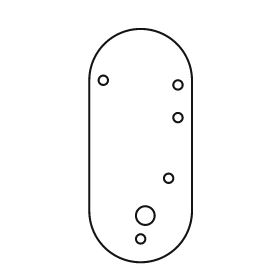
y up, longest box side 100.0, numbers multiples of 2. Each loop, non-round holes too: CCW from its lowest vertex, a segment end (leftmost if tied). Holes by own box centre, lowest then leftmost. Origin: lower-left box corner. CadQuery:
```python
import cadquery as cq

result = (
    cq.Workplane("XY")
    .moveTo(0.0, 22.0)
    .threePointArc((22.0, 0.0), (44.0, 22.0))
    .lineTo(44.0, 78.0)
    .threePointArc((22.0, 100.0), (0.0, 78.0))
    .close()
    .moveTo(22.0, 10.0)
    .circle(2.0)
    .moveTo(24.0, 20.0)
    .circle(4.0)
    .moveTo(34.0, 36.0)
    .circle(2.0)
    .moveTo(38.0, 62.0)
    .circle(2.0)
    .moveTo(38.0, 76.0)
    .circle(2.0)
    .moveTo(6.0, 78.0)
    .circle(2.0)
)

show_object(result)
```